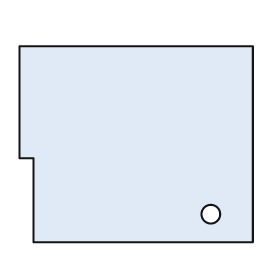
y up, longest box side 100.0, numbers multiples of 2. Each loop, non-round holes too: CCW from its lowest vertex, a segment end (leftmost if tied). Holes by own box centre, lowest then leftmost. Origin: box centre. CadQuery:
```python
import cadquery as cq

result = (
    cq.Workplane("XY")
    .moveTo(-44.0, -42.0)
    .lineTo(50.0, -42.0)
    .lineTo(50.0, 42.0)
    .lineTo(-50.0, 42.0)
    .lineTo(-50.0, -6.0)
    .lineTo(-44.0, -6.0)
    .close()
    .moveTo(32.0, -30.0)
    .circle(4.0)
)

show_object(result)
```